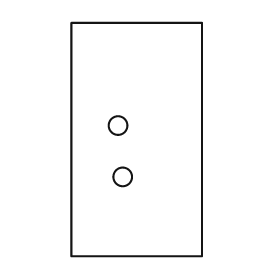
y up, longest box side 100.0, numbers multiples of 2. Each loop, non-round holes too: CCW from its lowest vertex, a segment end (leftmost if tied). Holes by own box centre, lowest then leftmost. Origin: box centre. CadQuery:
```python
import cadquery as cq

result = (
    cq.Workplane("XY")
    .moveTo(-28.0, -50.0)
    .lineTo(28.0, -50.0)
    .lineTo(28.0, 50.0)
    .lineTo(-28.0, 50.0)
    .close()
    .moveTo(-6.0, -16.0)
    .circle(4.0)
    .moveTo(-8.0, 6.0)
    .circle(4.0)
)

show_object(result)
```